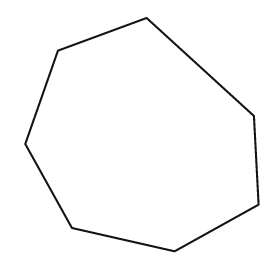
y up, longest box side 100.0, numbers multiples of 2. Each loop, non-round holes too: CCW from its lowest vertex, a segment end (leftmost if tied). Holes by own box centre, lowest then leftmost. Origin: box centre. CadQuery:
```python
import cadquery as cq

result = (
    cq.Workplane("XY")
    .moveTo(14.0, -50.0)
    .lineTo(50.0, -30.0)
    .lineTo(48.0, 8.0)
    .lineTo(2.0, 50.0)
    .lineTo(-36.0, 36.0)
    .lineTo(-50.0, -4.0)
    .lineTo(-30.0, -40.0)
    .close()
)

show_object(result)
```